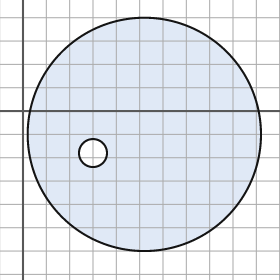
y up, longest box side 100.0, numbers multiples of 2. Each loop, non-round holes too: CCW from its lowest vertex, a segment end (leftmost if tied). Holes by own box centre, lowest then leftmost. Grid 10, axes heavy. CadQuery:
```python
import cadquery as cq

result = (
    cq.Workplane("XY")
    .moveTo(52.0, -10.0)
    .circle(50.0)
    .moveTo(30.0, -18.0)
    .circle(6.0)
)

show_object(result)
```